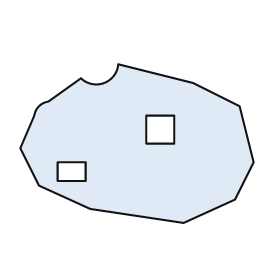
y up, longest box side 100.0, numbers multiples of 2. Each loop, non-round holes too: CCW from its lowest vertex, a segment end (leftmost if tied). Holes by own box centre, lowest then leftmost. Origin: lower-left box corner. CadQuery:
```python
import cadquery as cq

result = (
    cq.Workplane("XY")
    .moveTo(70.0, 0.0)
    .lineTo(92.0, 10.0)
    .lineTo(100.0, 26.0)
    .lineTo(94.0, 50.0)
    .lineTo(74.0, 60.0)
    .lineTo(42.0, 68.0)
    .threePointArc((36.0, 60.0), (26.0, 62.0))
    .lineTo(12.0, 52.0)
    .threePointArc((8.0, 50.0), (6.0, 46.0))
    .lineTo(0.0, 32.0)
    .lineTo(8.0, 16.0)
    .lineTo(30.0, 6.0)
    .close()
    .moveTo(16.0, 18.0)
    .lineTo(28.0, 18.0)
    .lineTo(28.0, 26.0)
    .lineTo(16.0, 26.0)
    .close()
    .moveTo(54.0, 34.0)
    .lineTo(66.0, 34.0)
    .lineTo(66.0, 46.0)
    .lineTo(54.0, 46.0)
    .close()
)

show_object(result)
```